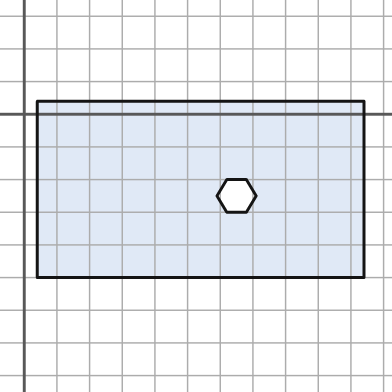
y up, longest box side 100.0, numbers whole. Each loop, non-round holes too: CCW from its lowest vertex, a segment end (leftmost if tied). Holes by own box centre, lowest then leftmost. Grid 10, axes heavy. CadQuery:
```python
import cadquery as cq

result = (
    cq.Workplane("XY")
    .moveTo(4.0, -50.0)
    .lineTo(104.0, -50.0)
    .lineTo(104.0, 4.0)
    .lineTo(4.0, 4.0)
    .close()
    .moveTo(62.0, -30.0)
    .lineTo(68.0, -30.0)
    .lineTo(71.0, -25.0)
    .lineTo(68.0, -20.0)
    .lineTo(62.0, -20.0)
    .lineTo(59.0, -25.0)
    .close()
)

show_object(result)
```